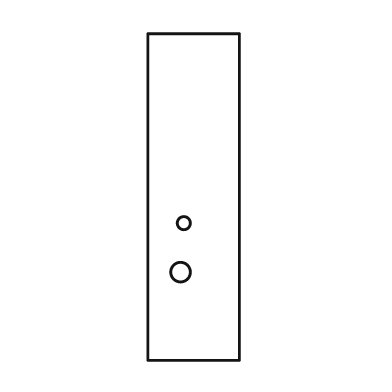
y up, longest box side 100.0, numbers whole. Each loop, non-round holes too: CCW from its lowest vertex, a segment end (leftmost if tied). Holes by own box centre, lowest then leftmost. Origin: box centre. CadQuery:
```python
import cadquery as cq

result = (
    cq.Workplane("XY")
    .moveTo(-14.0, -50.0)
    .lineTo(14.0, -50.0)
    .lineTo(14.0, 50.0)
    .lineTo(-14.0, 50.0)
    .close()
    .moveTo(-4.0, -23.0)
    .circle(3.0)
    .moveTo(-3.0, -8.0)
    .circle(2.0)
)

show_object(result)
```